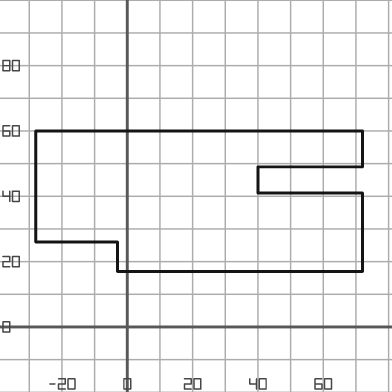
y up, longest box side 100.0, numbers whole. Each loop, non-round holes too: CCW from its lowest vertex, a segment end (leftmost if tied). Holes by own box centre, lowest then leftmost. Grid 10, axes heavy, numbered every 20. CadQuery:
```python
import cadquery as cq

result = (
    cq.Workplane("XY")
    .moveTo(-3.0, 17.0)
    .lineTo(72.0, 17.0)
    .lineTo(72.0, 41.0)
    .lineTo(40.0, 41.0)
    .lineTo(40.0, 49.0)
    .lineTo(72.0, 49.0)
    .lineTo(72.0, 60.0)
    .lineTo(-28.0, 60.0)
    .lineTo(-28.0, 26.0)
    .lineTo(-3.0, 26.0)
    .close()
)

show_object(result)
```